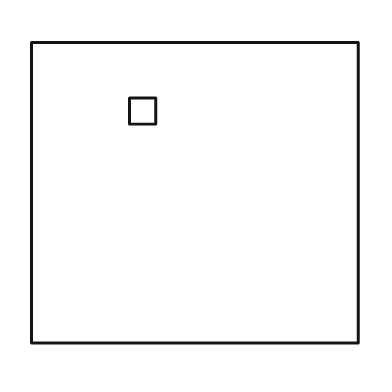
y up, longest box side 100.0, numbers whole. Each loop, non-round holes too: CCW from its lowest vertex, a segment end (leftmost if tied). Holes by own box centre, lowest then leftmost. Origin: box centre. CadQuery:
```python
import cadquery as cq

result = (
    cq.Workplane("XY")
    .moveTo(-50.0, -46.0)
    .lineTo(50.0, -46.0)
    .lineTo(50.0, 46.0)
    .lineTo(-50.0, 46.0)
    .close()
    .moveTo(-20.0, 21.0)
    .lineTo(-12.0, 21.0)
    .lineTo(-12.0, 29.0)
    .lineTo(-20.0, 29.0)
    .close()
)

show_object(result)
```